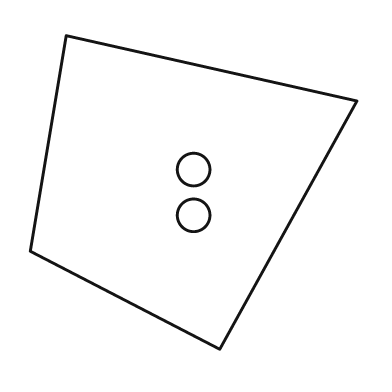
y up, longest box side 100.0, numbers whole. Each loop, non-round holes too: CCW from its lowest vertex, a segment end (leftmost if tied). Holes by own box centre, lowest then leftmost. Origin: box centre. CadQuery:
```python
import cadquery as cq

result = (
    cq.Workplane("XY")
    .moveTo(8.0, -48.0)
    .lineTo(50.0, 28.0)
    .lineTo(-39.0, 48.0)
    .lineTo(-50.0, -18.0)
    .close()
    .moveTo(0.0, -7.0)
    .circle(5.0)
    .moveTo(0.0, 7.0)
    .circle(5.0)
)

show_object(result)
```